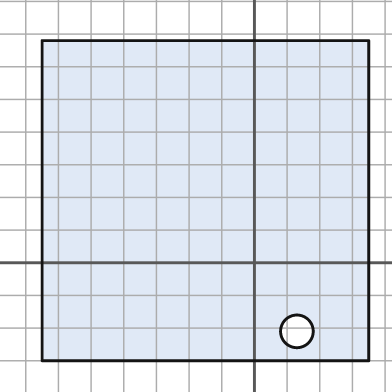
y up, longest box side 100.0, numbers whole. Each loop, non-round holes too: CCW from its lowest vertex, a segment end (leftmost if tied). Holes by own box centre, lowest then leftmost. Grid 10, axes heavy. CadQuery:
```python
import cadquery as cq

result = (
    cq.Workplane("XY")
    .moveTo(-65.0, -30.0)
    .lineTo(35.0, -30.0)
    .lineTo(35.0, 68.0)
    .lineTo(-65.0, 68.0)
    .close()
    .moveTo(13.0, -21.0)
    .circle(5.0)
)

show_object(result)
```